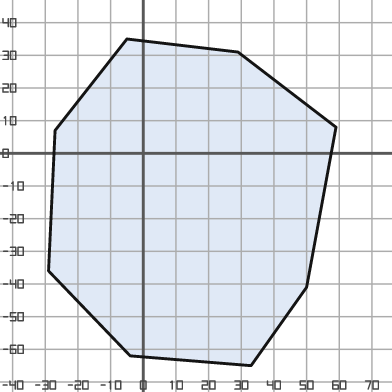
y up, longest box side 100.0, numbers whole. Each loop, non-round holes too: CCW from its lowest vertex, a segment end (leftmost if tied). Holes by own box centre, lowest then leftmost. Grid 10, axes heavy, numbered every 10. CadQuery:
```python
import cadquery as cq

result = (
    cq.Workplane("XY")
    .moveTo(33.0, -65.0)
    .lineTo(50.0, -41.0)
    .lineTo(59.0, 8.0)
    .lineTo(29.0, 31.0)
    .lineTo(-5.0, 35.0)
    .lineTo(-27.0, 7.0)
    .lineTo(-29.0, -36.0)
    .lineTo(-4.0, -62.0)
    .close()
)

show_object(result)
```